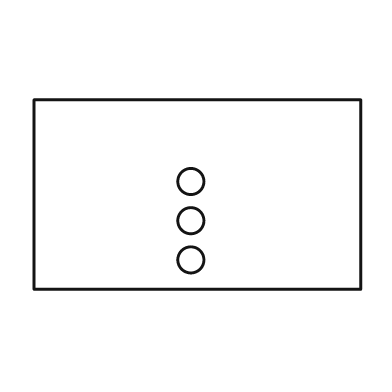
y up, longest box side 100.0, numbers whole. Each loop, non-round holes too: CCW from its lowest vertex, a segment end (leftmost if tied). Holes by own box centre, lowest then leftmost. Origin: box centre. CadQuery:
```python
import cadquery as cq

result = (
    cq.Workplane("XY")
    .moveTo(-50.0, -29.0)
    .lineTo(50.0, -29.0)
    .lineTo(50.0, 29.0)
    .lineTo(-50.0, 29.0)
    .close()
    .moveTo(-2.0, -20.0)
    .circle(4.0)
    .moveTo(-2.0, -8.0)
    .circle(4.0)
    .moveTo(-2.0, 4.0)
    .circle(4.0)
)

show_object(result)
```